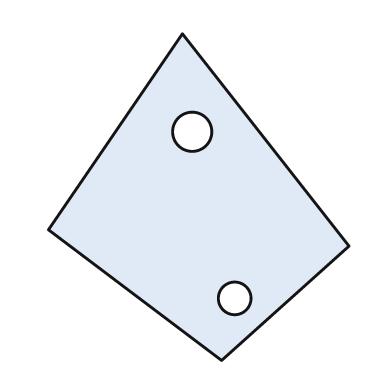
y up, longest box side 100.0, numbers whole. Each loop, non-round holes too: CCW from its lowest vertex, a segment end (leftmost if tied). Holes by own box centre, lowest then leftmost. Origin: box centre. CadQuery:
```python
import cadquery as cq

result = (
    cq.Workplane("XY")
    .moveTo(7.0, -50.0)
    .lineTo(46.0, -15.0)
    .lineTo(-5.0, 50.0)
    .lineTo(-46.0, -10.0)
    .close()
    .moveTo(11.0, -31.0)
    .circle(5.0)
    .moveTo(-2.0, 20.0)
    .circle(6.0)
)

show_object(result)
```